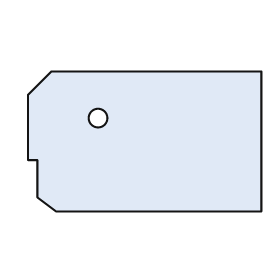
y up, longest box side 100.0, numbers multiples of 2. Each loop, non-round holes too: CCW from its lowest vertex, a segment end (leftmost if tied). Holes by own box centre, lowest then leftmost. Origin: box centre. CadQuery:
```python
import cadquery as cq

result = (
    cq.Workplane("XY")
    .moveTo(-38.0, -30.0)
    .lineTo(50.0, -30.0)
    .lineTo(50.0, 30.0)
    .lineTo(-40.0, 30.0)
    .lineTo(-50.0, 20.0)
    .lineTo(-50.0, -8.0)
    .lineTo(-46.0, -8.0)
    .lineTo(-46.0, -24.0)
    .close()
    .moveTo(-20.0, 10.0)
    .circle(4.0)
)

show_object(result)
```